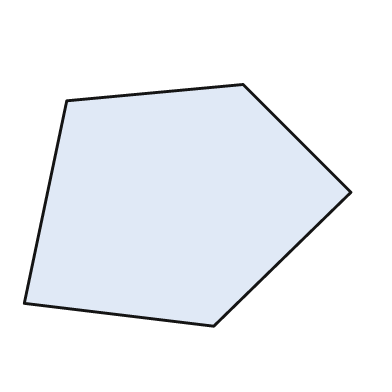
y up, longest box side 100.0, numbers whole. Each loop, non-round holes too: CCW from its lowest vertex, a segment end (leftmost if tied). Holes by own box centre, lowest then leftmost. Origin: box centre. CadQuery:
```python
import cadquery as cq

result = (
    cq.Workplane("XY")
    .moveTo(8.0, -37.0)
    .lineTo(50.0, 4.0)
    .lineTo(17.0, 37.0)
    .lineTo(-37.0, 32.0)
    .lineTo(-50.0, -30.0)
    .close()
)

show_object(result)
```